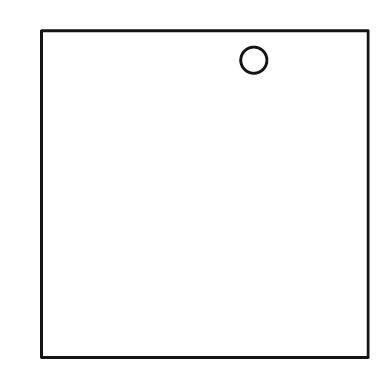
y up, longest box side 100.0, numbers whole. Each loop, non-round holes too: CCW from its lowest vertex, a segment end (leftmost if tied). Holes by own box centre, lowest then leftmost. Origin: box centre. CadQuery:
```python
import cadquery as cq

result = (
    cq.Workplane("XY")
    .moveTo(-50.0, -50.0)
    .lineTo(50.0, -50.0)
    .lineTo(50.0, 50.0)
    .lineTo(-50.0, 50.0)
    .close()
    .moveTo(15.0, 41.0)
    .circle(4.0)
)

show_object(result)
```